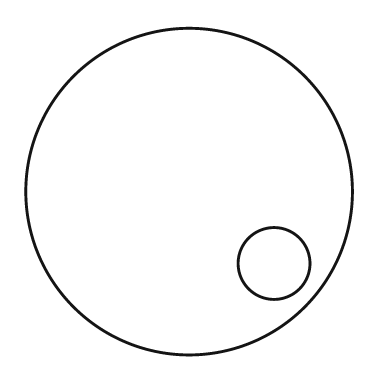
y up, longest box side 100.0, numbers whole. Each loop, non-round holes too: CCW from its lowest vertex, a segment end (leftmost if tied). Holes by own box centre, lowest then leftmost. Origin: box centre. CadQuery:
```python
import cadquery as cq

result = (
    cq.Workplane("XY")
    .moveTo(0.0, 0.0)
    .circle(50.0)
    .moveTo(26.0, -22.0)
    .circle(11.0)
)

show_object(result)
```